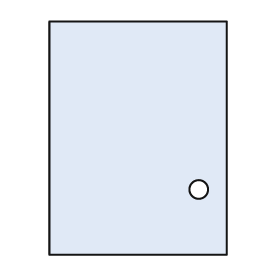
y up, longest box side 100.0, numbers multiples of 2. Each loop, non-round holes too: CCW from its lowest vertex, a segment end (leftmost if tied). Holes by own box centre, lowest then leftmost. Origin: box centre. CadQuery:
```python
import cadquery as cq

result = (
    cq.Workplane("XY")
    .moveTo(-38.0, -50.0)
    .lineTo(38.0, -50.0)
    .lineTo(38.0, 50.0)
    .lineTo(-38.0, 50.0)
    .close()
    .moveTo(26.0, -22.0)
    .circle(4.0)
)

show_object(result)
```